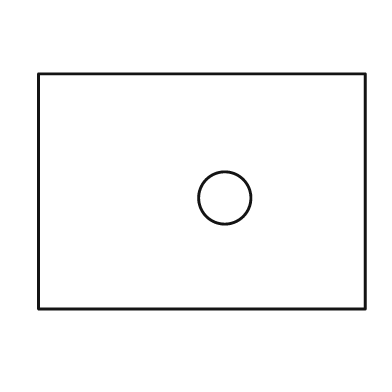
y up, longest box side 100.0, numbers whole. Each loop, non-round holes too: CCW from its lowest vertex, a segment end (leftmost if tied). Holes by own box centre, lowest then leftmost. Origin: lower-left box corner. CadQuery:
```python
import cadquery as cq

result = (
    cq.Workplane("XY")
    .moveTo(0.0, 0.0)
    .lineTo(100.0, 0.0)
    .lineTo(100.0, 72.0)
    .lineTo(0.0, 72.0)
    .close()
    .moveTo(57.0, 34.0)
    .circle(8.0)
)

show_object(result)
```